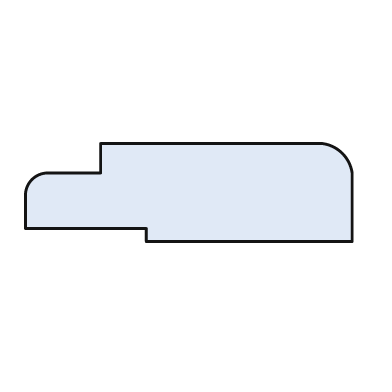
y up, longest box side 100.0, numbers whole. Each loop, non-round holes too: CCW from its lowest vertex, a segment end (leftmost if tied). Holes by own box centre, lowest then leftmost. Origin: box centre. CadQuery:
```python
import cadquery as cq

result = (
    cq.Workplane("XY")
    .moveTo(-13.0, -15.0)
    .lineTo(50.0, -15.0)
    .lineTo(50.0, 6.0)
    .threePointArc((47.0, 12.0), (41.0, 15.0))
    .lineTo(-27.0, 15.0)
    .lineTo(-27.0, 6.0)
    .lineTo(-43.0, 6.0)
    .threePointArc((-48.0, 4.0), (-50.0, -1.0))
    .lineTo(-50.0, -11.0)
    .lineTo(-13.0, -11.0)
    .close()
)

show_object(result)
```